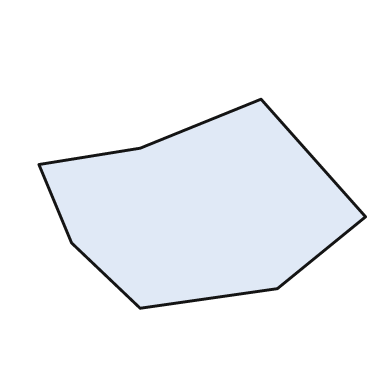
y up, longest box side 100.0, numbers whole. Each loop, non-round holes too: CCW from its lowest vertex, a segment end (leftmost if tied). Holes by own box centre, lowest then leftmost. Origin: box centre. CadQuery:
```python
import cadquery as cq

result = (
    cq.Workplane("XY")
    .moveTo(-19.0, -32.0)
    .lineTo(23.0, -26.0)
    .lineTo(50.0, -4.0)
    .lineTo(18.0, 32.0)
    .lineTo(-19.0, 17.0)
    .lineTo(-50.0, 12.0)
    .lineTo(-40.0, -12.0)
    .close()
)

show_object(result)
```